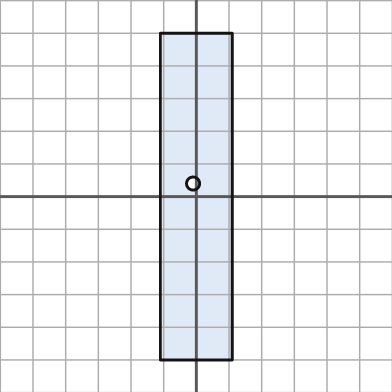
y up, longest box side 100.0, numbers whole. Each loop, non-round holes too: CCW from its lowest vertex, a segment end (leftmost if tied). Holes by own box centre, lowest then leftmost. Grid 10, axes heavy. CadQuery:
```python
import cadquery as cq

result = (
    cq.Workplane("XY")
    .moveTo(-11.0, -50.0)
    .lineTo(11.0, -50.0)
    .lineTo(11.0, 50.0)
    .lineTo(-11.0, 50.0)
    .close()
    .moveTo(-1.0, 4.0)
    .circle(2.0)
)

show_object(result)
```